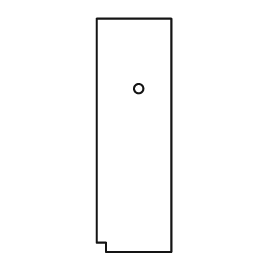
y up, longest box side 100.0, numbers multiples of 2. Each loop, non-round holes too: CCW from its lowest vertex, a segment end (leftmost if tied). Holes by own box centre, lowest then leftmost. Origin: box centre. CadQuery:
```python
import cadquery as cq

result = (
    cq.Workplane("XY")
    .moveTo(-12.0, -50.0)
    .lineTo(16.0, -50.0)
    .lineTo(16.0, 50.0)
    .lineTo(-16.0, 50.0)
    .lineTo(-16.0, -46.0)
    .lineTo(-12.0, -46.0)
    .close()
    .moveTo(2.0, 20.0)
    .circle(2.0)
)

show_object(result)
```